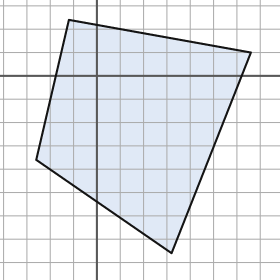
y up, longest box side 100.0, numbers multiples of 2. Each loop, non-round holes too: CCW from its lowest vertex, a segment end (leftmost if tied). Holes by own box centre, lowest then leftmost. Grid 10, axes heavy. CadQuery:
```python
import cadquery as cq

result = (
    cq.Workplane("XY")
    .moveTo(32.0, -76.0)
    .lineTo(66.0, 10.0)
    .lineTo(-12.0, 24.0)
    .lineTo(-26.0, -36.0)
    .close()
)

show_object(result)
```